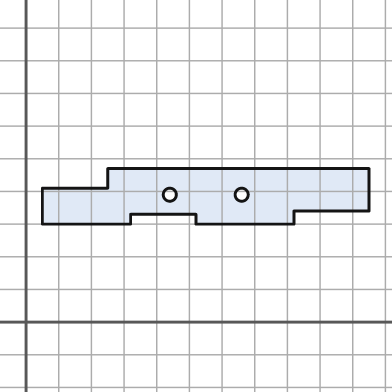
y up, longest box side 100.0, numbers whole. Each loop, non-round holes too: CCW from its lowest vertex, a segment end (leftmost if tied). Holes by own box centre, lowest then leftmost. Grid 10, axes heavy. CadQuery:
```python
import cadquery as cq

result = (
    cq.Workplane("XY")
    .moveTo(5.0, 30.0)
    .lineTo(32.0, 30.0)
    .lineTo(32.0, 33.0)
    .lineTo(52.0, 33.0)
    .lineTo(52.0, 30.0)
    .lineTo(82.0, 30.0)
    .lineTo(82.0, 34.0)
    .lineTo(105.0, 34.0)
    .lineTo(105.0, 47.0)
    .lineTo(25.0, 47.0)
    .lineTo(25.0, 41.0)
    .lineTo(5.0, 41.0)
    .close()
    .moveTo(44.0, 39.0)
    .circle(2.0)
    .moveTo(66.0, 39.0)
    .circle(2.0)
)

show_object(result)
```